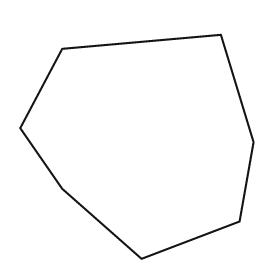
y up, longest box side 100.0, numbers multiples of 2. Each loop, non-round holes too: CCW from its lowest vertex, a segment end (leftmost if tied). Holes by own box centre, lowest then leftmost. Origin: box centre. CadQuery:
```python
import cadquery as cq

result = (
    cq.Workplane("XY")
    .moveTo(2.0, -48.0)
    .lineTo(44.0, -32.0)
    .lineTo(50.0, 2.0)
    .lineTo(36.0, 48.0)
    .lineTo(-32.0, 42.0)
    .lineTo(-50.0, 8.0)
    .lineTo(-32.0, -18.0)
    .close()
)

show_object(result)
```